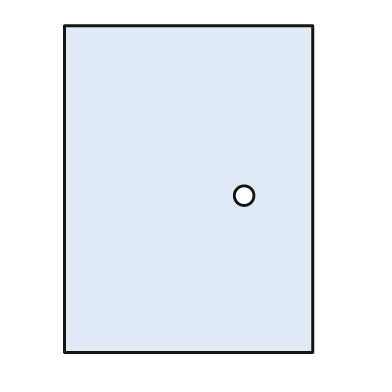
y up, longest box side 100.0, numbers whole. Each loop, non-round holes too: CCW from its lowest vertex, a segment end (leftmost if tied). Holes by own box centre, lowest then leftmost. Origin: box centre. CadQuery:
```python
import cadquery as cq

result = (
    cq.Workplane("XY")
    .moveTo(-38.0, -50.0)
    .lineTo(38.0, -50.0)
    .lineTo(38.0, 50.0)
    .lineTo(-38.0, 50.0)
    .close()
    .moveTo(17.0, -2.0)
    .circle(3.0)
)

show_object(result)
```